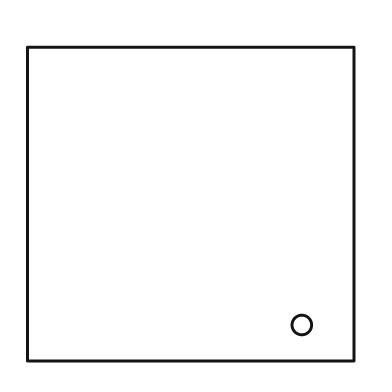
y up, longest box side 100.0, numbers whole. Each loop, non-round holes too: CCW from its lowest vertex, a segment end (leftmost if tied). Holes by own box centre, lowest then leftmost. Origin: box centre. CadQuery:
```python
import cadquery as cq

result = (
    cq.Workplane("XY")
    .moveTo(-50.0, -48.0)
    .lineTo(50.0, -48.0)
    .lineTo(50.0, 48.0)
    .lineTo(-50.0, 48.0)
    .close()
    .moveTo(34.0, -37.0)
    .circle(3.0)
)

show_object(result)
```